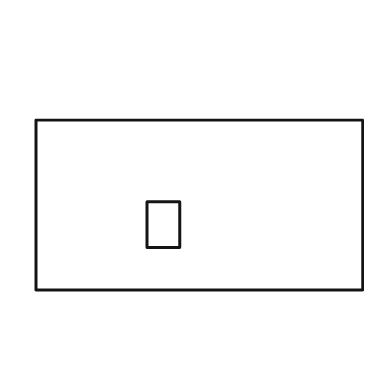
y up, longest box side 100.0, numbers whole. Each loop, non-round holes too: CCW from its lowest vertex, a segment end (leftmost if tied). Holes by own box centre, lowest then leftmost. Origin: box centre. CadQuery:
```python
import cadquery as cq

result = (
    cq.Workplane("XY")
    .moveTo(-50.0, -26.0)
    .lineTo(50.0, -26.0)
    .lineTo(50.0, 26.0)
    .lineTo(-50.0, 26.0)
    .close()
    .moveTo(-16.0, -13.0)
    .lineTo(-6.0, -13.0)
    .lineTo(-6.0, 1.0)
    .lineTo(-16.0, 1.0)
    .close()
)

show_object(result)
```